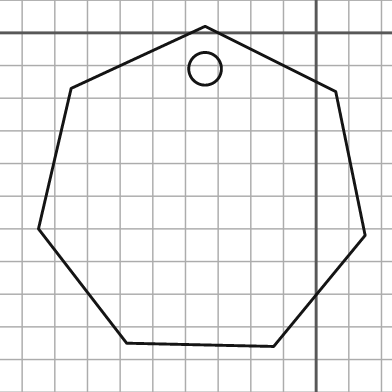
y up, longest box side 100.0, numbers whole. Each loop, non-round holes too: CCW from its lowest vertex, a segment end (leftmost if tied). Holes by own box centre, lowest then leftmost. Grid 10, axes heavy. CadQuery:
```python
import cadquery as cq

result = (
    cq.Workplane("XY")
    .moveTo(-13.0, -96.0)
    .lineTo(15.0, -62.0)
    .lineTo(6.0, -18.0)
    .lineTo(-34.0, 2.0)
    .lineTo(-75.0, -17.0)
    .lineTo(-85.0, -60.0)
    .lineTo(-58.0, -95.0)
    .close()
    .moveTo(-34.0, -11.0)
    .circle(5.0)
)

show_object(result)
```